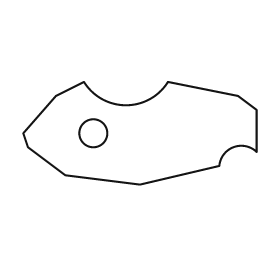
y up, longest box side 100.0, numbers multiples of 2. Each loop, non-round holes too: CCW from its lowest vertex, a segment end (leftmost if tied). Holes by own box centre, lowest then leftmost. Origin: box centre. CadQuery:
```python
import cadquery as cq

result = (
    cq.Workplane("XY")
    .moveTo(0.0, -22.0)
    .lineTo(34.0, -14.0)
    .threePointArc((40.0, -6.0), (50.0, -8.0))
    .lineTo(50.0, 10.0)
    .lineTo(42.0, 16.0)
    .lineTo(12.0, 22.0)
    .threePointArc((-6.0, 12.0), (-24.0, 22.0))
    .lineTo(-36.0, 16.0)
    .lineTo(-50.0, 0.0)
    .lineTo(-48.0, -6.0)
    .lineTo(-32.0, -18.0)
    .close()
    .moveTo(-20.0, 0.0)
    .circle(6.0)
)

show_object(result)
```